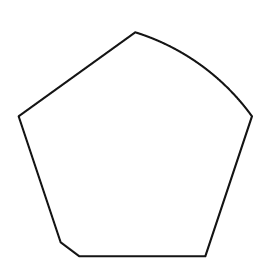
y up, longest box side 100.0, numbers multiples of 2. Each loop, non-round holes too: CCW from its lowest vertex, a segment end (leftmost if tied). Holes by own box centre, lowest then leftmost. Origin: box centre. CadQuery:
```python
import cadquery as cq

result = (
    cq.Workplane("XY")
    .moveTo(-24.0, -48.0)
    .lineTo(30.0, -48.0)
    .lineTo(50.0, 12.0)
    .threePointArc((28.0, 34.0), (0.0, 48.0))
    .lineTo(-50.0, 12.0)
    .lineTo(-32.0, -42.0)
    .close()
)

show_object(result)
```